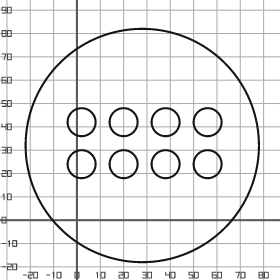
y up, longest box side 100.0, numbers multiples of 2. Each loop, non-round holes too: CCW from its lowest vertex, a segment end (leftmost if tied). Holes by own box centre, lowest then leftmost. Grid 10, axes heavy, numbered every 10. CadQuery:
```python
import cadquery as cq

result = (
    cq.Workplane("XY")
    .moveTo(28.0, 32.0)
    .circle(50.0)
    .moveTo(2.0, 24.0)
    .circle(6.0)
    .moveTo(20.0, 24.0)
    .circle(6.0)
    .moveTo(38.0, 24.0)
    .circle(6.0)
    .moveTo(56.0, 24.0)
    .circle(6.0)
    .moveTo(2.0, 42.0)
    .circle(6.0)
    .moveTo(20.0, 42.0)
    .circle(6.0)
    .moveTo(38.0, 42.0)
    .circle(6.0)
    .moveTo(56.0, 42.0)
    .circle(6.0)
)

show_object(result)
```